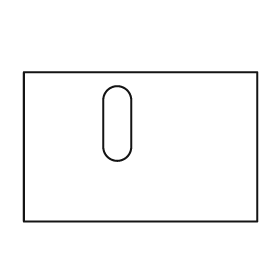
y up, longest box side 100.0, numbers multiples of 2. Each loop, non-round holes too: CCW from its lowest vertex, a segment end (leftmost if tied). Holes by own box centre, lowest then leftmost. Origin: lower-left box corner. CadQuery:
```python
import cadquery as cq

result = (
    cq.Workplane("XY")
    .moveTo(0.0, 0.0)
    .lineTo(100.0, 0.0)
    .lineTo(100.0, 64.0)
    .lineTo(0.0, 64.0)
    .close()
    .moveTo(34.0, 32.0)
    .threePointArc((40.0, 26.0), (46.0, 32.0))
    .lineTo(46.0, 52.0)
    .threePointArc((40.0, 58.0), (34.0, 52.0))
    .close()
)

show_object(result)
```